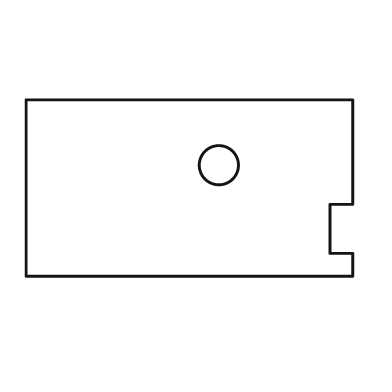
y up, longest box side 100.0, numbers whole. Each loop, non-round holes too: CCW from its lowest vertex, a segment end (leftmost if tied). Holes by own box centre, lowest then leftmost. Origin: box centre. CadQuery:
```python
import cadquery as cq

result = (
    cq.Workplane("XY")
    .moveTo(-50.0, -27.0)
    .lineTo(50.0, -27.0)
    .lineTo(50.0, -20.0)
    .lineTo(43.0, -20.0)
    .lineTo(43.0, -5.0)
    .lineTo(50.0, -5.0)
    .lineTo(50.0, 27.0)
    .lineTo(-50.0, 27.0)
    .close()
    .moveTo(9.0, 7.0)
    .circle(6.0)
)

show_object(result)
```